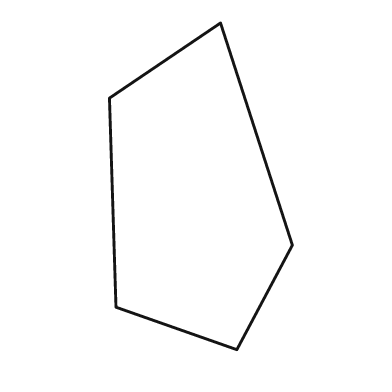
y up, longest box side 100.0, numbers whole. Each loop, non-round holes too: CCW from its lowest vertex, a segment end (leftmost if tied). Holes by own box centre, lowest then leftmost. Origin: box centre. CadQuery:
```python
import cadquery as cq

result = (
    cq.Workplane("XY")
    .moveTo(11.0, -50.0)
    .lineTo(28.0, -18.0)
    .lineTo(6.0, 50.0)
    .lineTo(-28.0, 27.0)
    .lineTo(-26.0, -37.0)
    .close()
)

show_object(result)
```